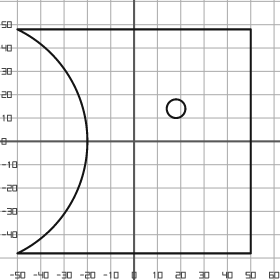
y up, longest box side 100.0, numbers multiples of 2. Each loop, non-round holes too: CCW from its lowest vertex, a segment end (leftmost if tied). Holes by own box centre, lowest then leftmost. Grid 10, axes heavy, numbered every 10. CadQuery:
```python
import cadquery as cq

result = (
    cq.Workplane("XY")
    .moveTo(-50.0, -48.0)
    .lineTo(50.0, -48.0)
    .lineTo(50.0, 48.0)
    .lineTo(-50.0, 48.0)
    .threePointArc((-20.0, 0.0), (-50.0, -48.0))
    .close()
    .moveTo(18.0, 14.0)
    .circle(4.0)
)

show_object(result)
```